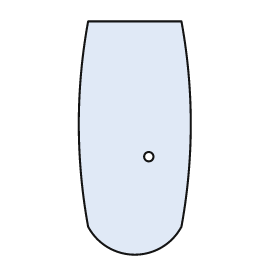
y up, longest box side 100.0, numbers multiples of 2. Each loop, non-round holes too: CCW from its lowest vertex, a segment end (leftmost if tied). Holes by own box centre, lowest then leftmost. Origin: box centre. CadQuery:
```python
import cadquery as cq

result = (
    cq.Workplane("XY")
    .moveTo(-20.0, -38.0)
    .threePointArc((0.0, -50.0), (20.0, -38.0))
    .threePointArc((24.0, 6.0), (20.0, 50.0))
    .lineTo(-20.0, 50.0)
    .threePointArc((-24.0, 6.0), (-20.0, -38.0))
    .close()
    .moveTo(6.0, -8.0)
    .circle(2.0)
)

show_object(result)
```